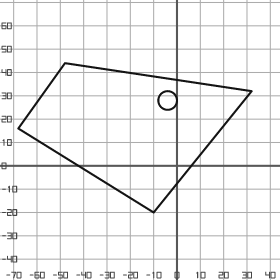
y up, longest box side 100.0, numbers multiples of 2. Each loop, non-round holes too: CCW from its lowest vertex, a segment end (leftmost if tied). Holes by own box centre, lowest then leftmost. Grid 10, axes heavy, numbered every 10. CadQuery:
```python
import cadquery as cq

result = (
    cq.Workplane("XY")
    .moveTo(-10.0, -20.0)
    .lineTo(32.0, 32.0)
    .lineTo(-48.0, 44.0)
    .lineTo(-68.0, 16.0)
    .close()
    .moveTo(-4.0, 28.0)
    .circle(4.0)
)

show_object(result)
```